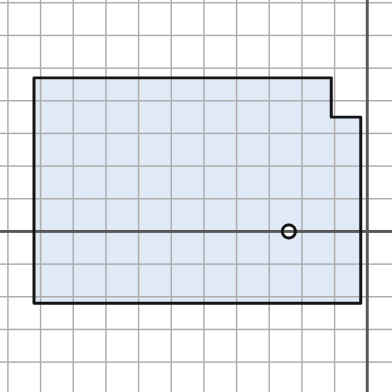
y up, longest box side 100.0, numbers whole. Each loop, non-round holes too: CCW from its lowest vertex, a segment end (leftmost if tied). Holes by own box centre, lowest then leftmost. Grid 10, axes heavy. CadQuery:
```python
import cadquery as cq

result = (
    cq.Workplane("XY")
    .moveTo(-102.0, -22.0)
    .lineTo(-2.0, -22.0)
    .lineTo(-2.0, 35.0)
    .lineTo(-11.0, 35.0)
    .lineTo(-11.0, 47.0)
    .lineTo(-102.0, 47.0)
    .close()
    .moveTo(-24.0, 0.0)
    .circle(2.0)
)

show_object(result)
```